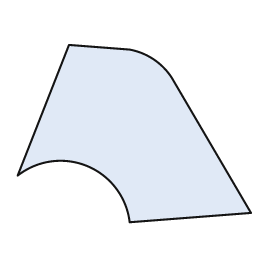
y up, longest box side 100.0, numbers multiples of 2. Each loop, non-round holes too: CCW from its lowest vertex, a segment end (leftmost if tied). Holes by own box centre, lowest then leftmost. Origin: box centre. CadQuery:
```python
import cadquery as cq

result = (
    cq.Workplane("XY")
    .moveTo(-2.0, -38.0)
    .lineTo(50.0, -34.0)
    .lineTo(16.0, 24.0)
    .threePointArc((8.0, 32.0), (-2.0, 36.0))
    .lineTo(-28.0, 38.0)
    .lineTo(-50.0, -18.0)
    .threePointArc((-20.0, -14.0), (-2.0, -38.0))
    .close()
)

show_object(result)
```